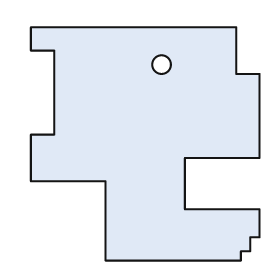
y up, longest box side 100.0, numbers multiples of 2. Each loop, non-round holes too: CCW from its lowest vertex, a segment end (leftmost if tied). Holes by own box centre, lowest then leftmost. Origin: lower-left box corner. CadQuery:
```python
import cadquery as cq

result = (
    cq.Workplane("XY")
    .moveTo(32.0, 0.0)
    .lineTo(90.0, 0.0)
    .lineTo(90.0, 4.0)
    .lineTo(94.0, 4.0)
    .lineTo(94.0, 10.0)
    .lineTo(98.0, 10.0)
    .lineTo(98.0, 22.0)
    .lineTo(66.0, 22.0)
    .lineTo(66.0, 44.0)
    .lineTo(98.0, 44.0)
    .lineTo(98.0, 80.0)
    .lineTo(88.0, 80.0)
    .lineTo(88.0, 100.0)
    .lineTo(0.0, 100.0)
    .lineTo(0.0, 90.0)
    .lineTo(10.0, 90.0)
    .lineTo(10.0, 54.0)
    .lineTo(0.0, 54.0)
    .lineTo(0.0, 34.0)
    .lineTo(32.0, 34.0)
    .close()
    .moveTo(56.0, 84.0)
    .circle(4.0)
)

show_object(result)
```